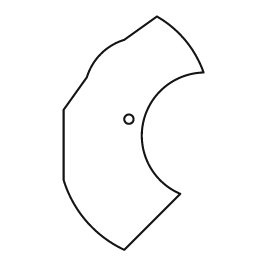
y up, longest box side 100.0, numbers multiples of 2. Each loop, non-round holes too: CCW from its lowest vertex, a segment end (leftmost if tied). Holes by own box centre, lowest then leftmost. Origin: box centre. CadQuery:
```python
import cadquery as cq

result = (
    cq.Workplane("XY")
    .moveTo(-4.0, -50.0)
    .lineTo(20.0, -26.0)
    .threePointArc((4.0, 4.0), (30.0, 26.0))
    .threePointArc((22.0, 40.0), (10.0, 50.0))
    .lineTo(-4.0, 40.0)
    .threePointArc((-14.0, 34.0), (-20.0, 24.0))
    .lineTo(-30.0, 10.0)
    .lineTo(-30.0, -20.0)
    .threePointArc((-20.0, -38.0), (-4.0, -50.0))
    .close()
    .moveTo(-2.0, 6.0)
    .circle(2.0)
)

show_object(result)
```